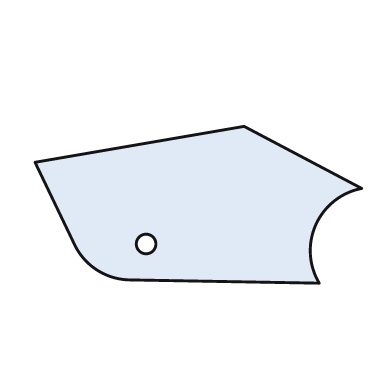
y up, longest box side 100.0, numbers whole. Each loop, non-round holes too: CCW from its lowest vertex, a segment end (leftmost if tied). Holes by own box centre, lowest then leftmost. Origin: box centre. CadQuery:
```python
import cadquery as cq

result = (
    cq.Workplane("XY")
    .moveTo(37.0, -24.0)
    .threePointArc((36.0, -6.0), (50.0, 5.0))
    .lineTo(14.0, 24.0)
    .lineTo(-50.0, 13.0)
    .lineTo(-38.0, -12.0)
    .threePointArc((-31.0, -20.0), (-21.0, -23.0))
    .close()
    .moveTo(-16.0, -12.0)
    .circle(3.0)
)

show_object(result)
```